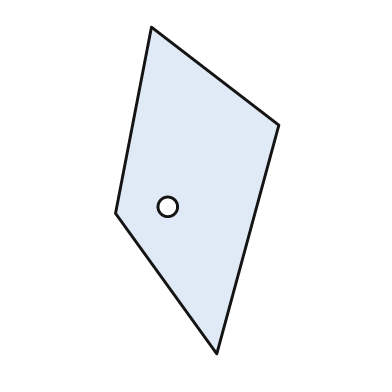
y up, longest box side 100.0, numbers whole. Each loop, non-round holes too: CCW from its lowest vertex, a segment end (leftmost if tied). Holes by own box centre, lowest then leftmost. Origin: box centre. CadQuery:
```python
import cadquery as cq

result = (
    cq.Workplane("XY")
    .moveTo(6.0, -50.0)
    .lineTo(25.0, 20.0)
    .lineTo(-14.0, 50.0)
    .lineTo(-25.0, -7.0)
    .close()
    .moveTo(-9.0, -5.0)
    .circle(3.0)
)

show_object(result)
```